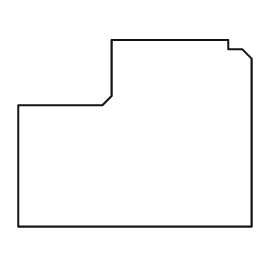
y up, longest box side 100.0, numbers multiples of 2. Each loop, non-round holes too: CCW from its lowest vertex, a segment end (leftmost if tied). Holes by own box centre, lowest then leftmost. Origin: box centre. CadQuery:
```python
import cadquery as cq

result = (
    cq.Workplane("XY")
    .moveTo(-50.0, -40.0)
    .lineTo(50.0, -40.0)
    .lineTo(50.0, 32.0)
    .lineTo(46.0, 36.0)
    .lineTo(40.0, 36.0)
    .lineTo(40.0, 40.0)
    .lineTo(-10.0, 40.0)
    .lineTo(-10.0, 16.0)
    .lineTo(-14.0, 12.0)
    .lineTo(-50.0, 12.0)
    .close()
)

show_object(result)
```